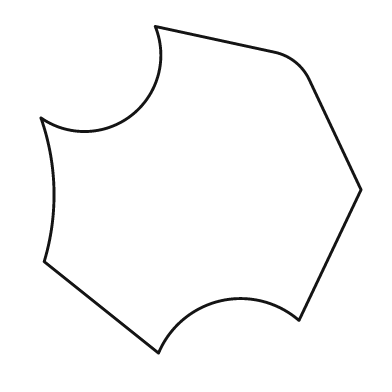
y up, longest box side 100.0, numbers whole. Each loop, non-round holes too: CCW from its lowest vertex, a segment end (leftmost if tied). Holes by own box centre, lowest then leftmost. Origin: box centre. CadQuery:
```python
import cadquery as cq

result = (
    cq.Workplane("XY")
    .moveTo(-13.0, -50.0)
    .threePointArc((6.0, -34.0), (30.0, -40.0))
    .lineTo(49.0, 0.0)
    .lineTo(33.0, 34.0)
    .threePointArc((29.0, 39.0), (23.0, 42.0))
    .lineTo(-14.0, 50.0)
    .threePointArc((-21.0, 23.0), (-49.0, 22.0))
    .threePointArc((-45.0, 0.0), (-48.0, -22.0))
    .close()
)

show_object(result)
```